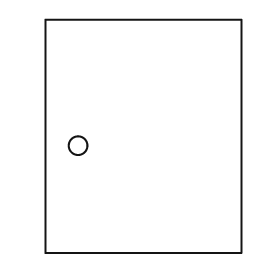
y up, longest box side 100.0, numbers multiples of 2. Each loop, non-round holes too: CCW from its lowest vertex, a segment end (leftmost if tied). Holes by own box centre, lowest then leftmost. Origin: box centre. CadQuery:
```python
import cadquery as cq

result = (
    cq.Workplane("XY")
    .moveTo(-42.0, -50.0)
    .lineTo(42.0, -50.0)
    .lineTo(42.0, 50.0)
    .lineTo(-42.0, 50.0)
    .close()
    .moveTo(-28.0, -4.0)
    .circle(4.0)
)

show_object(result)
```